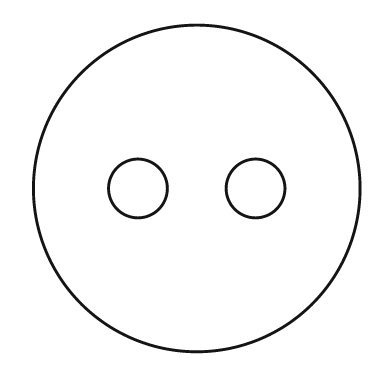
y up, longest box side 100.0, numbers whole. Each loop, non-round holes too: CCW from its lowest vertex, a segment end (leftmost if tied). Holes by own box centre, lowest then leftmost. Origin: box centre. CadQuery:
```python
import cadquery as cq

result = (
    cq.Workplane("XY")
    .moveTo(0.0, 0.0)
    .circle(50.0)
    .moveTo(-18.0, 0.0)
    .circle(9.0)
    .moveTo(18.0, 0.0)
    .circle(9.0)
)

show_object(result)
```